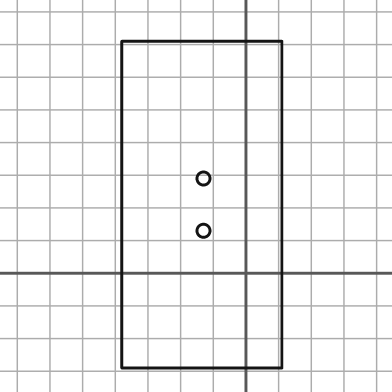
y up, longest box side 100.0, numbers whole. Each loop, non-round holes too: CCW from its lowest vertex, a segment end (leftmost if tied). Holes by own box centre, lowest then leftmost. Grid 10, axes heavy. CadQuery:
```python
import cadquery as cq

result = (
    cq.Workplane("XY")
    .moveTo(-38.0, -29.0)
    .lineTo(11.0, -29.0)
    .lineTo(11.0, 71.0)
    .lineTo(-38.0, 71.0)
    .close()
    .moveTo(-13.0, 13.0)
    .circle(2.0)
    .moveTo(-13.0, 29.0)
    .circle(2.0)
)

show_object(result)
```